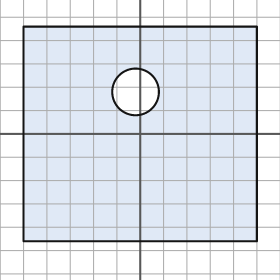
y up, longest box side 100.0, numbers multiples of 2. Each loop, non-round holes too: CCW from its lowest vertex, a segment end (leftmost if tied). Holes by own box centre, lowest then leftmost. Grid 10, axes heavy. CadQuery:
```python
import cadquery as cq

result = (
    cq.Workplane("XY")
    .moveTo(-50.0, -46.0)
    .lineTo(50.0, -46.0)
    .lineTo(50.0, 46.0)
    .lineTo(-50.0, 46.0)
    .close()
    .moveTo(-2.0, 18.0)
    .circle(10.0)
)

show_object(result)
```